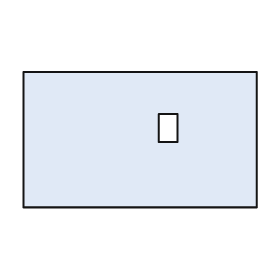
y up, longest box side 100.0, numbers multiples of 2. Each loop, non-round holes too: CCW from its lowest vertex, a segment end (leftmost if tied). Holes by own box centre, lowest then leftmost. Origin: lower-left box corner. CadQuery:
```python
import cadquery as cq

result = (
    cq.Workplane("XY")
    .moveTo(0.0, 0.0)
    .lineTo(100.0, 0.0)
    .lineTo(100.0, 58.0)
    .lineTo(0.0, 58.0)
    .close()
    .moveTo(58.0, 28.0)
    .lineTo(66.0, 28.0)
    .lineTo(66.0, 40.0)
    .lineTo(58.0, 40.0)
    .close()
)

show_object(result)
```